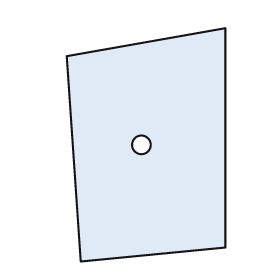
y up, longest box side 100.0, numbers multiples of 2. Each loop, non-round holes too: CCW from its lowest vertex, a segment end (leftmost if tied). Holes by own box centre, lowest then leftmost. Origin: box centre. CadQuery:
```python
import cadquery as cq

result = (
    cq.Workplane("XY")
    .moveTo(-28.0, -50.0)
    .lineTo(34.0, -44.0)
    .lineTo(34.0, 50.0)
    .lineTo(-34.0, 38.0)
    .close()
    .moveTo(-2.0, 0.0)
    .circle(4.0)
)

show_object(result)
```